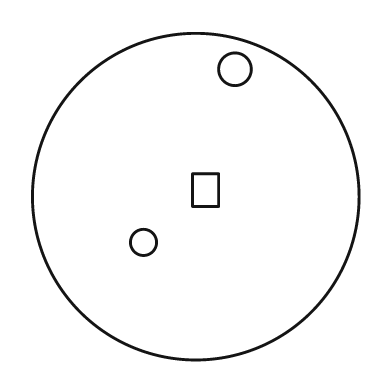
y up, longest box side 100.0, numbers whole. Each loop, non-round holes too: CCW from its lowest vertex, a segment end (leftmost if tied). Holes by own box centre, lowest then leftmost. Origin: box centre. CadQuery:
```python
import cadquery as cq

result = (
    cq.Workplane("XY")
    .moveTo(0.0, 0.0)
    .circle(50.0)
    .moveTo(-16.0, -14.0)
    .circle(4.0)
    .moveTo(-1.0, -3.0)
    .lineTo(7.0, -3.0)
    .lineTo(7.0, 7.0)
    .lineTo(-1.0, 7.0)
    .close()
    .moveTo(12.0, 39.0)
    .circle(5.0)
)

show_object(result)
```